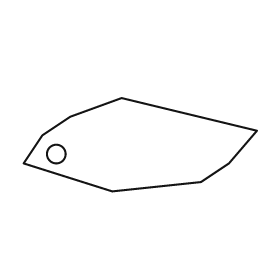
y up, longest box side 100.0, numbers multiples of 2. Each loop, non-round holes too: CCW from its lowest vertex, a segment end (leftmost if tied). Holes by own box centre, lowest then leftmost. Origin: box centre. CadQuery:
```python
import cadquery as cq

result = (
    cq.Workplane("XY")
    .moveTo(-12.0, -20.0)
    .lineTo(26.0, -16.0)
    .lineTo(38.0, -8.0)
    .lineTo(50.0, 6.0)
    .lineTo(-8.0, 20.0)
    .lineTo(-30.0, 12.0)
    .lineTo(-42.0, 4.0)
    .lineTo(-50.0, -8.0)
    .close()
    .moveTo(-36.0, -4.0)
    .circle(4.0)
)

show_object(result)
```